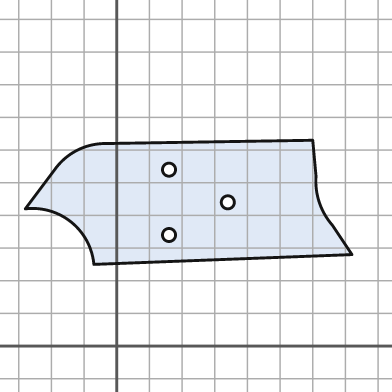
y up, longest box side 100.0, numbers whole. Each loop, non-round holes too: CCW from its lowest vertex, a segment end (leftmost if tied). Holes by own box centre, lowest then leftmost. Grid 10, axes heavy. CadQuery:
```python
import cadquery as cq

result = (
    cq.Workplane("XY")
    .moveTo(-7.0, 25.0)
    .lineTo(72.0, 28.0)
    .lineTo(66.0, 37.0)
    .threePointArc((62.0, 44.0), (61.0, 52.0))
    .lineTo(60.0, 63.0)
    .lineTo(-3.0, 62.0)
    .threePointArc((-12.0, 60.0), (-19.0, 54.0))
    .lineTo(-28.0, 42.0)
    .threePointArc((-14.0, 38.0), (-7.0, 25.0))
    .close()
    .moveTo(16.0, 34.0)
    .circle(2.0)
    .moveTo(34.0, 44.0)
    .circle(2.0)
    .moveTo(16.0, 54.0)
    .circle(2.0)
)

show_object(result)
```